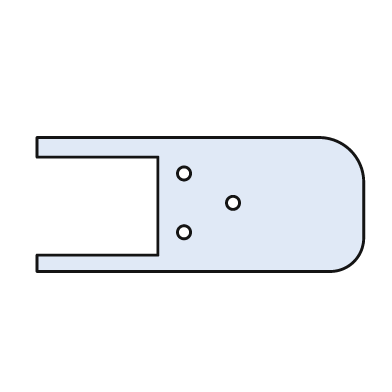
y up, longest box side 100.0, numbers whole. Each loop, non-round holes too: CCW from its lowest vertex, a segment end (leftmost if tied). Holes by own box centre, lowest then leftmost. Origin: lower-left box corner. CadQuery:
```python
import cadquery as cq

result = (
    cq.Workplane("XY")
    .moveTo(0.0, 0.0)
    .lineTo(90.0, 0.0)
    .threePointArc((97.0, 3.0), (100.0, 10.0))
    .lineTo(100.0, 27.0)
    .threePointArc((96.0, 37.0), (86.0, 41.0))
    .lineTo(0.0, 41.0)
    .lineTo(0.0, 35.0)
    .lineTo(37.0, 35.0)
    .lineTo(37.0, 5.0)
    .lineTo(0.0, 5.0)
    .close()
    .moveTo(45.0, 12.0)
    .circle(2.0)
    .moveTo(60.0, 21.0)
    .circle(2.0)
    .moveTo(45.0, 30.0)
    .circle(2.0)
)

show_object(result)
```